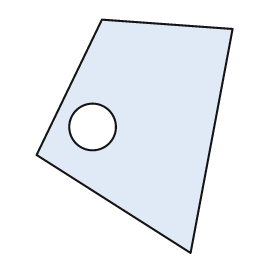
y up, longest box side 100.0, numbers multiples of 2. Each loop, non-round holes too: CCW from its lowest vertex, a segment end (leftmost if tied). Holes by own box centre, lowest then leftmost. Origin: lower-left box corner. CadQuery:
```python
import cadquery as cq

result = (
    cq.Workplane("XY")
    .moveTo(66.0, 0.0)
    .lineTo(84.0, 96.0)
    .lineTo(28.0, 100.0)
    .lineTo(0.0, 42.0)
    .close()
    .moveTo(24.0, 54.0)
    .circle(10.0)
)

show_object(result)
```